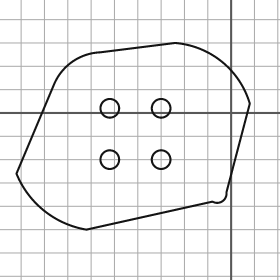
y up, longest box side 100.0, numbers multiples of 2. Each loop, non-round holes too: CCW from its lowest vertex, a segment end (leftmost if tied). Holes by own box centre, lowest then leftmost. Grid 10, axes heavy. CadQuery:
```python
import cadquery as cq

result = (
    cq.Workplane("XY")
    .moveTo(-62.0, -50.0)
    .lineTo(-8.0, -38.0)
    .threePointArc((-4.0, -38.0), (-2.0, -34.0))
    .lineTo(8.0, 4.0)
    .threePointArc((-4.0, 22.0), (-24.0, 30.0))
    .lineTo(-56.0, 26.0)
    .threePointArc((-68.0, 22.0), (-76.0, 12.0))
    .lineTo(-92.0, -26.0)
    .threePointArc((-80.0, -42.0), (-62.0, -50.0))
    .close()
    .moveTo(-52.0, -20.0)
    .circle(4.0)
    .moveTo(-30.0, -20.0)
    .circle(4.0)
    .moveTo(-52.0, 2.0)
    .circle(4.0)
    .moveTo(-30.0, 2.0)
    .circle(4.0)
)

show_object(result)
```